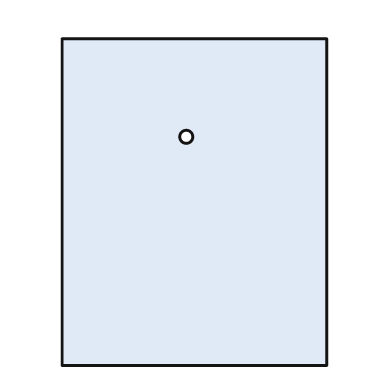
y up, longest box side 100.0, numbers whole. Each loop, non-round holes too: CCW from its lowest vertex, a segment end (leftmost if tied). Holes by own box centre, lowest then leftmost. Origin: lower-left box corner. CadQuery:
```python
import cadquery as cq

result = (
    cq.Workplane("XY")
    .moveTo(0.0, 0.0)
    .lineTo(81.0, 0.0)
    .lineTo(81.0, 100.0)
    .lineTo(0.0, 100.0)
    .close()
    .moveTo(38.0, 70.0)
    .circle(2.0)
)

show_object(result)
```